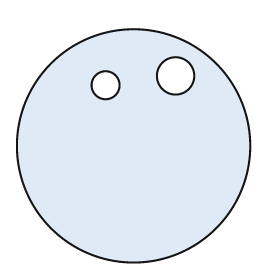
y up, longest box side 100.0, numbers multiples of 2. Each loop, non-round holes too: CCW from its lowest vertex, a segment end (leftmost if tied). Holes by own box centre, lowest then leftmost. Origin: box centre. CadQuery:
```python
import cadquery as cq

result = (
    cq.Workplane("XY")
    .moveTo(0.0, 0.0)
    .circle(50.0)
    .moveTo(-12.0, 26.0)
    .circle(6.0)
    .moveTo(18.0, 30.0)
    .circle(8.0)
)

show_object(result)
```